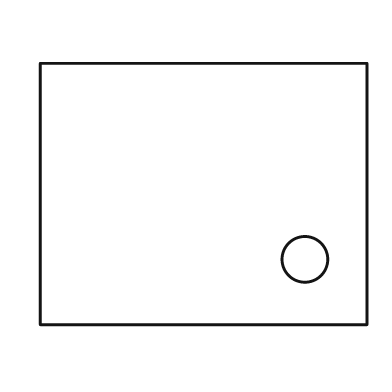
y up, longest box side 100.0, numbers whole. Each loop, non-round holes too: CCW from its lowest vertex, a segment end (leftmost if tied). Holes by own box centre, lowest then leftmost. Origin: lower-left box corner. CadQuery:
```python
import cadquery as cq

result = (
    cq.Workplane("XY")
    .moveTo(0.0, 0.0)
    .lineTo(100.0, 0.0)
    .lineTo(100.0, 80.0)
    .lineTo(0.0, 80.0)
    .close()
    .moveTo(81.0, 20.0)
    .circle(7.0)
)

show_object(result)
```